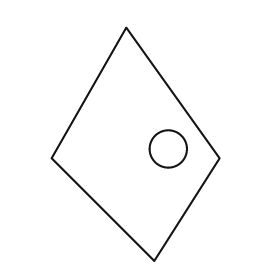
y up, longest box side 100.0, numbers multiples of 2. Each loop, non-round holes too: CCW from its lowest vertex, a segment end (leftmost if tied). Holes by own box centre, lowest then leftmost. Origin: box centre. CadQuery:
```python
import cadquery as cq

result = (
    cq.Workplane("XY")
    .moveTo(8.0, -50.0)
    .lineTo(36.0, -6.0)
    .lineTo(-4.0, 50.0)
    .lineTo(-36.0, -6.0)
    .close()
    .moveTo(14.0, -2.0)
    .circle(8.0)
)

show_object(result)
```